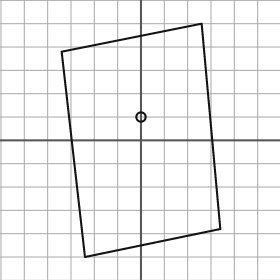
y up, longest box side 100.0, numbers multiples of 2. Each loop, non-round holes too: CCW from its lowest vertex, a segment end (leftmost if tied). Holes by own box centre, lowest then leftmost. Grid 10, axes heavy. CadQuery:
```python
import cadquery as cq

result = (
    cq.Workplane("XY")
    .moveTo(-24.0, -50.0)
    .lineTo(34.0, -38.0)
    .lineTo(26.0, 50.0)
    .lineTo(-34.0, 38.0)
    .close()
    .moveTo(0.0, 10.0)
    .circle(2.0)
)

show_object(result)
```